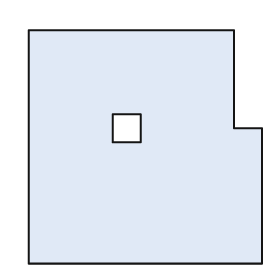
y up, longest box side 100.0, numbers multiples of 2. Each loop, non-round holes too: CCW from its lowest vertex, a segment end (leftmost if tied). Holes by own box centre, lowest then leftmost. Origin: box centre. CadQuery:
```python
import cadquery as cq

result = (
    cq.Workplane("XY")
    .moveTo(-50.0, -50.0)
    .lineTo(50.0, -50.0)
    .lineTo(50.0, 8.0)
    .lineTo(38.0, 8.0)
    .lineTo(38.0, 50.0)
    .lineTo(-50.0, 50.0)
    .close()
    .moveTo(-14.0, 2.0)
    .lineTo(-2.0, 2.0)
    .lineTo(-2.0, 14.0)
    .lineTo(-14.0, 14.0)
    .close()
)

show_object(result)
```